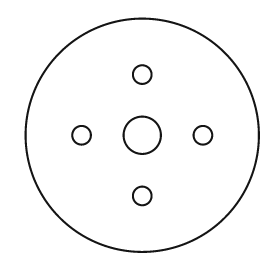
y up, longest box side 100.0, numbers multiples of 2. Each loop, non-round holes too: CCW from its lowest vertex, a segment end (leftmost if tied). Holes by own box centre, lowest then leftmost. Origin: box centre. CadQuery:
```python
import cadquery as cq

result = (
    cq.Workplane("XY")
    .moveTo(0.0, 0.0)
    .circle(50.0)
    .moveTo(0.0, -26.0)
    .circle(4.0)
    .moveTo(-26.0, 0.0)
    .circle(4.0)
    .moveTo(0.0, 0.0)
    .circle(8.0)
    .moveTo(26.0, 0.0)
    .circle(4.0)
    .moveTo(0.0, 26.0)
    .circle(4.0)
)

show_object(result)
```